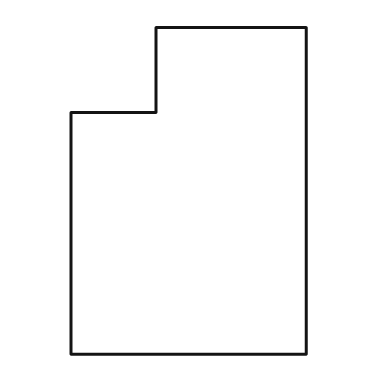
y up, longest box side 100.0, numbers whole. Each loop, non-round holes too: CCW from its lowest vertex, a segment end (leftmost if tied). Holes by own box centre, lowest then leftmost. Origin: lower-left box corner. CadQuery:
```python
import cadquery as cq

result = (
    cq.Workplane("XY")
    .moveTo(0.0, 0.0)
    .lineTo(72.0, 0.0)
    .lineTo(72.0, 100.0)
    .lineTo(26.0, 100.0)
    .lineTo(26.0, 74.0)
    .lineTo(0.0, 74.0)
    .close()
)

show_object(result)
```